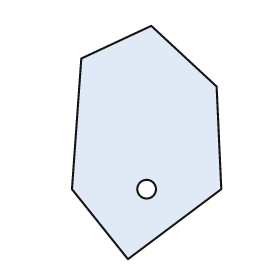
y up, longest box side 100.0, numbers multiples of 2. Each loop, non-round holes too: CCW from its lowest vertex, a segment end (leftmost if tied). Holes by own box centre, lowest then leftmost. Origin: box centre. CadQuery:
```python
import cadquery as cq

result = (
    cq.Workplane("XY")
    .moveTo(-8.0, -50.0)
    .lineTo(32.0, -20.0)
    .lineTo(30.0, 24.0)
    .lineTo(2.0, 50.0)
    .lineTo(-28.0, 36.0)
    .lineTo(-32.0, -20.0)
    .close()
    .moveTo(0.0, -20.0)
    .circle(4.0)
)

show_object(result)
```